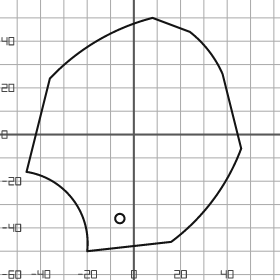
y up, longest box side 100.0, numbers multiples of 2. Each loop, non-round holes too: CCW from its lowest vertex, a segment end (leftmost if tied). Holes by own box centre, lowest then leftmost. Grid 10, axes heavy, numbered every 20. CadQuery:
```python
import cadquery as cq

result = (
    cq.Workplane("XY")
    .moveTo(-20.0, -50.0)
    .lineTo(16.0, -46.0)
    .threePointArc((34.0, -28.0), (46.0, -6.0))
    .lineTo(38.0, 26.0)
    .threePointArc((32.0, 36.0), (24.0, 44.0))
    .lineTo(8.0, 50.0)
    .threePointArc((-16.0, 40.0), (-36.0, 24.0))
    .lineTo(-46.0, -16.0)
    .threePointArc((-26.0, -28.0), (-20.0, -50.0))
    .close()
    .moveTo(-6.0, -36.0)
    .circle(2.0)
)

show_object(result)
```